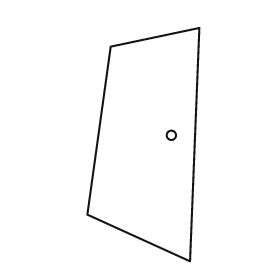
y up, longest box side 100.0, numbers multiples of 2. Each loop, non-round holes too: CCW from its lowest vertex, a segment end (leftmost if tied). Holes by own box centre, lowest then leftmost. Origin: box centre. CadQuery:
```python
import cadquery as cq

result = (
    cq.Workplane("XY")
    .moveTo(20.0, -50.0)
    .lineTo(24.0, 50.0)
    .lineTo(-14.0, 42.0)
    .lineTo(-24.0, -30.0)
    .close()
    .moveTo(12.0, 4.0)
    .circle(2.0)
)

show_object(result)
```